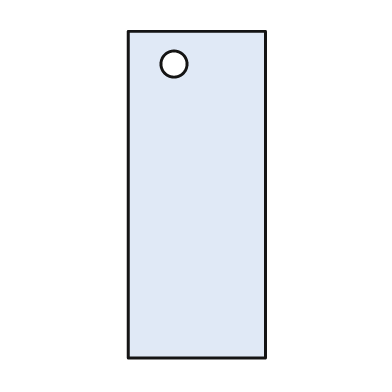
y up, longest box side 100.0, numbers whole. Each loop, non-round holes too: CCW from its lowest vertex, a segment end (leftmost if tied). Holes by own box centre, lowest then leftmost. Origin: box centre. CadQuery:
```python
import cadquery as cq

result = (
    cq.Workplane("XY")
    .moveTo(-21.0, -50.0)
    .lineTo(21.0, -50.0)
    .lineTo(21.0, 50.0)
    .lineTo(-21.0, 50.0)
    .close()
    .moveTo(-7.0, 40.0)
    .circle(4.0)
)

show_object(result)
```